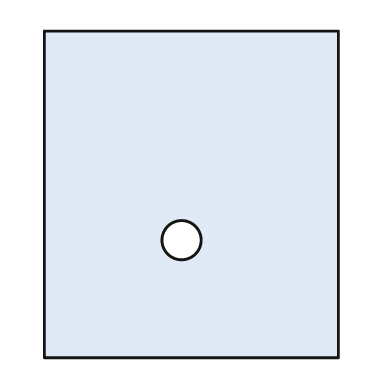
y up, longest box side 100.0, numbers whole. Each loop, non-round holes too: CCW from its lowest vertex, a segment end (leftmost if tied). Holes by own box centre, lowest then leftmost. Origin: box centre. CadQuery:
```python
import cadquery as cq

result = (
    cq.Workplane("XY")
    .moveTo(-45.0, -50.0)
    .lineTo(45.0, -50.0)
    .lineTo(45.0, 50.0)
    .lineTo(-45.0, 50.0)
    .close()
    .moveTo(-3.0, -14.0)
    .circle(6.0)
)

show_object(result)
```